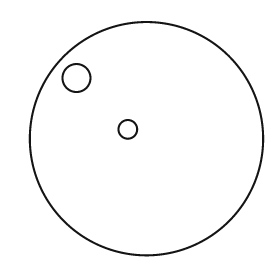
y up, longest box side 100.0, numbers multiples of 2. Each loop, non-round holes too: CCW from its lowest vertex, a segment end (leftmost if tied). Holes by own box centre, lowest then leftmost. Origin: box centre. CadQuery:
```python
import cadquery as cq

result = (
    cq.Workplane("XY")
    .moveTo(0.0, 0.0)
    .circle(50.0)
    .moveTo(-8.0, 4.0)
    .circle(4.0)
    .moveTo(-30.0, 26.0)
    .circle(6.0)
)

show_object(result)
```